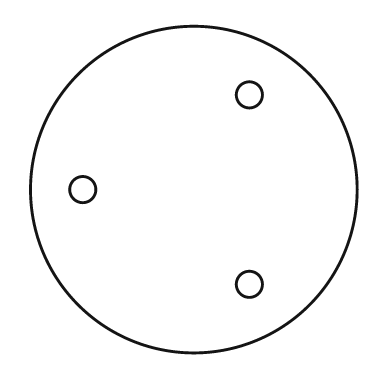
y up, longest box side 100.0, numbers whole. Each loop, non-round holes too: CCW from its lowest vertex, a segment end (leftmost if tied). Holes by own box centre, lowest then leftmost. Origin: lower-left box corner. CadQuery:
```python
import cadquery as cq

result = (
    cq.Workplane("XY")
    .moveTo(50.0, 50.0)
    .circle(50.0)
    .moveTo(67.0, 21.0)
    .circle(4.0)
    .moveTo(16.0, 50.0)
    .circle(4.0)
    .moveTo(67.0, 79.0)
    .circle(4.0)
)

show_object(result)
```